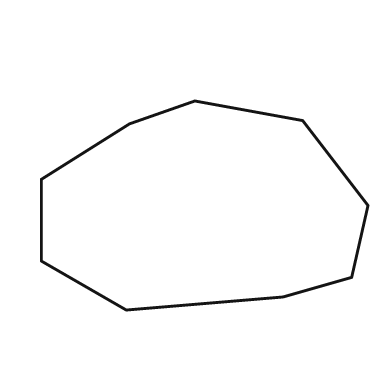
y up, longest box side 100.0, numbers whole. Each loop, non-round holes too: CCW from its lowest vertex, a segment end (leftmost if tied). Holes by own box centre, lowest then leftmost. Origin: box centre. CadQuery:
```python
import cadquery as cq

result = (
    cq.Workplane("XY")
    .moveTo(-24.0, -32.0)
    .lineTo(24.0, -28.0)
    .lineTo(45.0, -22.0)
    .lineTo(50.0, 0.0)
    .lineTo(30.0, 26.0)
    .lineTo(-3.0, 32.0)
    .lineTo(-23.0, 25.0)
    .lineTo(-50.0, 8.0)
    .lineTo(-50.0, -17.0)
    .close()
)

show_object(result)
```